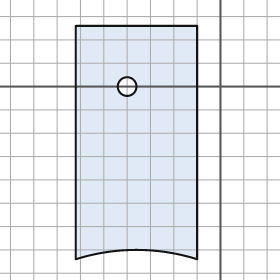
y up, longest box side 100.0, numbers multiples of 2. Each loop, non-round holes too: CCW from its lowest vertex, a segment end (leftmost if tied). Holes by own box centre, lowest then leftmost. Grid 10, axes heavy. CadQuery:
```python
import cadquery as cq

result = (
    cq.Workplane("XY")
    .moveTo(-62.0, -74.0)
    .threePointArc((-36.0, -70.0), (-10.0, -74.0))
    .lineTo(-10.0, 26.0)
    .lineTo(-62.0, 26.0)
    .close()
    .moveTo(-40.0, 0.0)
    .circle(4.0)
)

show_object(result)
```